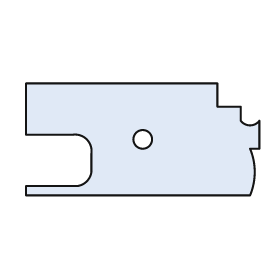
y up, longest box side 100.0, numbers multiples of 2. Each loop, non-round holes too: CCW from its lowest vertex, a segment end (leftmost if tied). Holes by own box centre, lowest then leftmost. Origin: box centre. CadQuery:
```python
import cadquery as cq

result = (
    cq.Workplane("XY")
    .moveTo(-50.0, -24.0)
    .lineTo(46.0, -24.0)
    .threePointArc((48.0, -14.0), (46.0, -4.0))
    .lineTo(50.0, -4.0)
    .lineTo(50.0, 8.0)
    .threePointArc((46.0, 6.0), (42.0, 8.0))
    .lineTo(42.0, 14.0)
    .lineTo(32.0, 14.0)
    .lineTo(32.0, 24.0)
    .lineTo(-50.0, 24.0)
    .lineTo(-50.0, 2.0)
    .lineTo(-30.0, 2.0)
    .threePointArc((-24.0, 0.0), (-22.0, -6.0))
    .lineTo(-22.0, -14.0)
    .threePointArc((-24.0, -18.0), (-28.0, -20.0))
    .lineTo(-50.0, -20.0)
    .close()
    .moveTo(0.0, 0.0)
    .circle(4.0)
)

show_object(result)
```